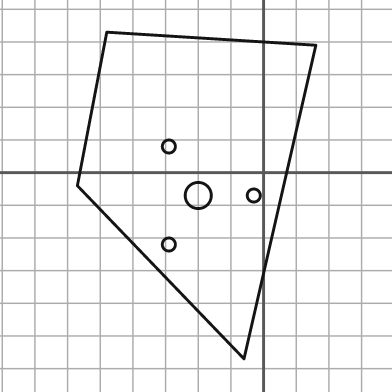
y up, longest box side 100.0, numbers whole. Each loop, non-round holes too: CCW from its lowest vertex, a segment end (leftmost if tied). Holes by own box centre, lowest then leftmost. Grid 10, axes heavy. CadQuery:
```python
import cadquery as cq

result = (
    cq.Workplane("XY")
    .moveTo(-6.0, -57.0)
    .lineTo(16.0, 39.0)
    .lineTo(-48.0, 43.0)
    .lineTo(-57.0, -4.0)
    .close()
    .moveTo(-29.0, -22.0)
    .circle(2.0)
    .moveTo(-20.0, -7.0)
    .circle(4.0)
    .moveTo(-3.0, -7.0)
    .circle(2.0)
    .moveTo(-29.0, 8.0)
    .circle(2.0)
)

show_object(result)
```